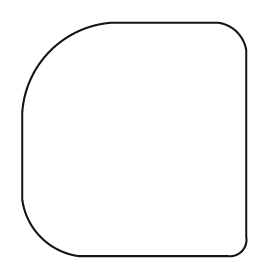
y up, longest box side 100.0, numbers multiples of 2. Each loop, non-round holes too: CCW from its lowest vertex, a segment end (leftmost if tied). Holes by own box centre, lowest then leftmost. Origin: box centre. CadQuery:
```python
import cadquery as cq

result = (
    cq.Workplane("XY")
    .moveTo(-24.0, -50.0)
    .lineTo(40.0, -50.0)
    .threePointArc((46.0, -48.0), (48.0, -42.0))
    .lineTo(48.0, 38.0)
    .threePointArc((44.0, 46.0), (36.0, 50.0))
    .lineTo(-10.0, 50.0)
    .threePointArc((-36.0, 38.0), (-48.0, 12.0))
    .lineTo(-48.0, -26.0)
    .threePointArc((-40.0, -42.0), (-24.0, -50.0))
    .close()
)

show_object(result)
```